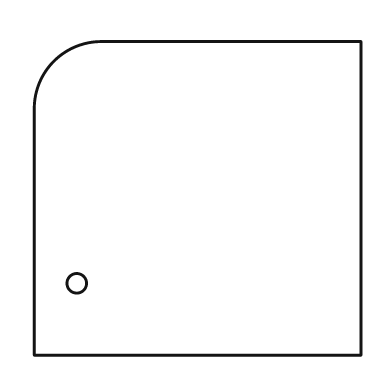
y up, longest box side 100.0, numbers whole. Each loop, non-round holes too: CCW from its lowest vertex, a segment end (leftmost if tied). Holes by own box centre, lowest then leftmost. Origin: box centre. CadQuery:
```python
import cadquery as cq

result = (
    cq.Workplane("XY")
    .moveTo(-50.0, -48.0)
    .lineTo(50.0, -48.0)
    .lineTo(50.0, 48.0)
    .lineTo(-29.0, 48.0)
    .threePointArc((-44.0, 42.0), (-50.0, 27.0))
    .close()
    .moveTo(-37.0, -26.0)
    .circle(3.0)
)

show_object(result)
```